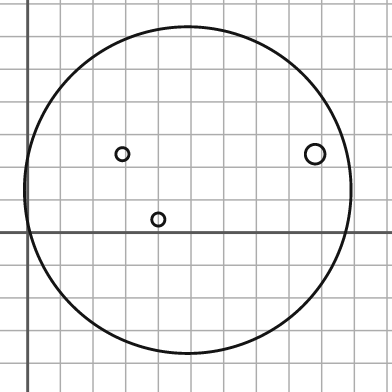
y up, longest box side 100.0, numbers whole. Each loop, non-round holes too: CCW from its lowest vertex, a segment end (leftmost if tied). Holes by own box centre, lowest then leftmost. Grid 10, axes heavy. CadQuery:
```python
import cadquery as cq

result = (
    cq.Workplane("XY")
    .moveTo(49.0, 13.0)
    .circle(50.0)
    .moveTo(40.0, 4.0)
    .circle(2.0)
    .moveTo(29.0, 24.0)
    .circle(2.0)
    .moveTo(88.0, 24.0)
    .circle(3.0)
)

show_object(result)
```